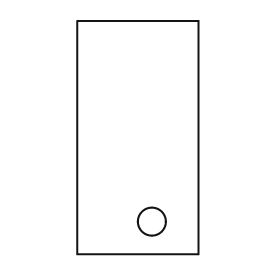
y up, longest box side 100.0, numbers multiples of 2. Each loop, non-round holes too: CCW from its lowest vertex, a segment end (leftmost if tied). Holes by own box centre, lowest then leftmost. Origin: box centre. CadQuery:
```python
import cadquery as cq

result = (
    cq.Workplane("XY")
    .moveTo(-26.0, -50.0)
    .lineTo(26.0, -50.0)
    .lineTo(26.0, 50.0)
    .lineTo(-26.0, 50.0)
    .close()
    .moveTo(6.0, -36.0)
    .circle(6.0)
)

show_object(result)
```